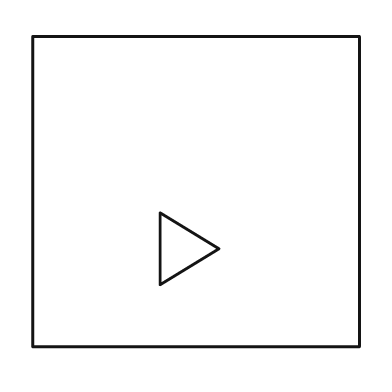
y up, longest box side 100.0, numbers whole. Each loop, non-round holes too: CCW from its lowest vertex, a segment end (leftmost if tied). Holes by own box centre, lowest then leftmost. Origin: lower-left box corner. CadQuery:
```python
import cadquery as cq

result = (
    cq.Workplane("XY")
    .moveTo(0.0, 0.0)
    .lineTo(100.0, 0.0)
    .lineTo(100.0, 95.0)
    .lineTo(0.0, 95.0)
    .close()
    .moveTo(39.0, 19.0)
    .lineTo(57.0, 30.0)
    .lineTo(39.0, 41.0)
    .close()
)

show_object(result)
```